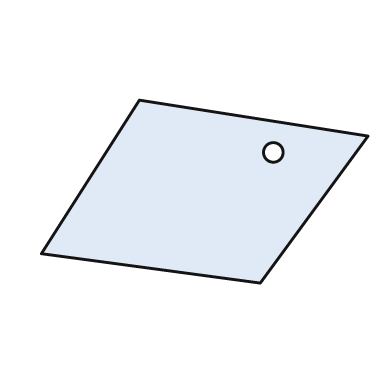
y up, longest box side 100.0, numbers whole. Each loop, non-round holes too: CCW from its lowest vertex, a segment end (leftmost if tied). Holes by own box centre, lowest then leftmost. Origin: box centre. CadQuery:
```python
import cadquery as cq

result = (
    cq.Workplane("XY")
    .moveTo(17.0, -28.0)
    .lineTo(50.0, 17.0)
    .lineTo(-20.0, 28.0)
    .lineTo(-50.0, -19.0)
    .close()
    .moveTo(21.0, 12.0)
    .circle(3.0)
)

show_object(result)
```